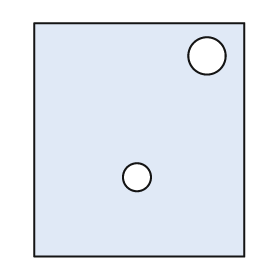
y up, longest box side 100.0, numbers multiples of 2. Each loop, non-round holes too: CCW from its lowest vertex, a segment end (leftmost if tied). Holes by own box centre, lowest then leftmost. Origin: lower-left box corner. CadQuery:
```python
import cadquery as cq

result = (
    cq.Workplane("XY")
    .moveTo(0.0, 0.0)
    .lineTo(90.0, 0.0)
    .lineTo(90.0, 100.0)
    .lineTo(0.0, 100.0)
    .close()
    .moveTo(44.0, 34.0)
    .circle(6.0)
    .moveTo(74.0, 86.0)
    .circle(8.0)
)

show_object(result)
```